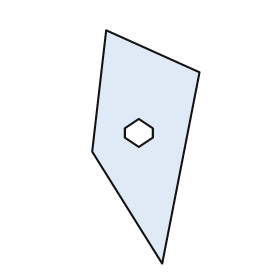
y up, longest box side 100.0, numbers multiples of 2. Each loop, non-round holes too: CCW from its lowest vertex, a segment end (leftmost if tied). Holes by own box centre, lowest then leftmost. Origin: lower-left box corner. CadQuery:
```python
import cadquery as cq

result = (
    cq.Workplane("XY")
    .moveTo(30.0, 0.0)
    .lineTo(46.0, 82.0)
    .lineTo(6.0, 100.0)
    .lineTo(0.0, 48.0)
    .close()
    .moveTo(20.0, 50.0)
    .lineTo(26.0, 54.0)
    .lineTo(26.0, 58.0)
    .lineTo(20.0, 62.0)
    .lineTo(14.0, 58.0)
    .lineTo(14.0, 54.0)
    .close()
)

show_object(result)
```